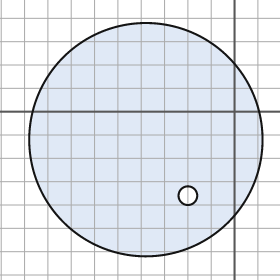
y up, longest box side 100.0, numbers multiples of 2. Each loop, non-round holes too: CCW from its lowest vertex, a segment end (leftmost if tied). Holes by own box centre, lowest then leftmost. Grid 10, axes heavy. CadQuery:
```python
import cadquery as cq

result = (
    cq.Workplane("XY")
    .moveTo(-38.0, -12.0)
    .circle(50.0)
    .moveTo(-20.0, -36.0)
    .circle(4.0)
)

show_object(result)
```